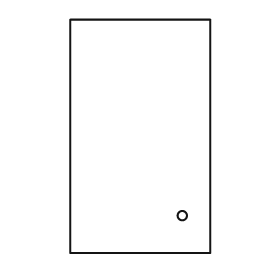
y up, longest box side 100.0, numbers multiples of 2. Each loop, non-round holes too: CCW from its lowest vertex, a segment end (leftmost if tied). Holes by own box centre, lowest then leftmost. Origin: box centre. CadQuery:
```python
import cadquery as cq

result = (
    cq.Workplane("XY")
    .moveTo(-30.0, -50.0)
    .lineTo(30.0, -50.0)
    .lineTo(30.0, 50.0)
    .lineTo(-30.0, 50.0)
    .close()
    .moveTo(18.0, -34.0)
    .circle(2.0)
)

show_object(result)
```